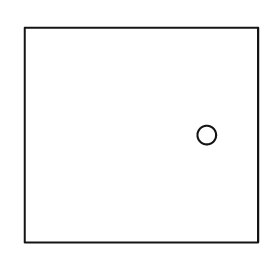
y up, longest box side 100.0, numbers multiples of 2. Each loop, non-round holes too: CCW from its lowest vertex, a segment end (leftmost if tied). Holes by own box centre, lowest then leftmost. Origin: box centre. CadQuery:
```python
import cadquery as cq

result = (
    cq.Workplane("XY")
    .moveTo(-50.0, -46.0)
    .lineTo(50.0, -46.0)
    .lineTo(50.0, 46.0)
    .lineTo(-50.0, 46.0)
    .close()
    .moveTo(28.0, 0.0)
    .circle(4.0)
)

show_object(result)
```